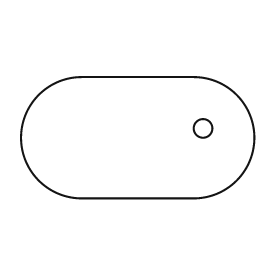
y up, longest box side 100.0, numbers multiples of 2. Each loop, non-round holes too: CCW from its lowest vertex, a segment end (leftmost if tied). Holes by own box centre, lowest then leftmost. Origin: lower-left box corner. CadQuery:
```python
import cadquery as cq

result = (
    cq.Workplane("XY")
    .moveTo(26.0, 0.0)
    .lineTo(74.0, 0.0)
    .threePointArc((100.0, 26.0), (74.0, 52.0))
    .lineTo(26.0, 52.0)
    .threePointArc((0.0, 26.0), (26.0, 0.0))
    .close()
    .moveTo(78.0, 30.0)
    .circle(4.0)
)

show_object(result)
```